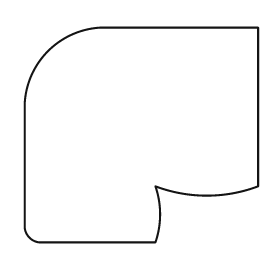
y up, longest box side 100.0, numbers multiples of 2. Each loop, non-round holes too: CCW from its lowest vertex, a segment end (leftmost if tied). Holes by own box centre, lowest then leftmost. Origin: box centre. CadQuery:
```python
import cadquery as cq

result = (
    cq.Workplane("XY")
    .moveTo(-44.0, -46.0)
    .lineTo(6.0, -46.0)
    .threePointArc((8.0, -34.0), (6.0, -22.0))
    .threePointArc((28.0, -26.0), (50.0, -22.0))
    .lineTo(50.0, 46.0)
    .lineTo(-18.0, 46.0)
    .threePointArc((-40.0, 36.0), (-50.0, 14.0))
    .lineTo(-50.0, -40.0)
    .threePointArc((-48.0, -44.0), (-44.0, -46.0))
    .close()
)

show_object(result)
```